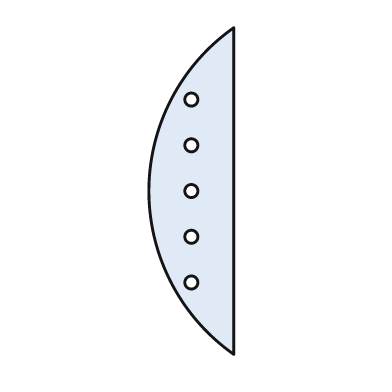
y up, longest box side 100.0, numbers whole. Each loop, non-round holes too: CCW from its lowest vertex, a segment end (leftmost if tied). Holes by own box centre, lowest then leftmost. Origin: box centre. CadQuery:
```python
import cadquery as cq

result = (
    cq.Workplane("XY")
    .moveTo(13.0, -50.0)
    .lineTo(13.0, 50.0)
    .threePointArc((-13.0, 0.0), (13.0, -50.0))
    .close()
    .moveTo(0.0, -28.0)
    .circle(2.0)
    .moveTo(0.0, -14.0)
    .circle(2.0)
    .moveTo(0.0, 0.0)
    .circle(2.0)
    .moveTo(0.0, 14.0)
    .circle(2.0)
    .moveTo(0.0, 28.0)
    .circle(2.0)
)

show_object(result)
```